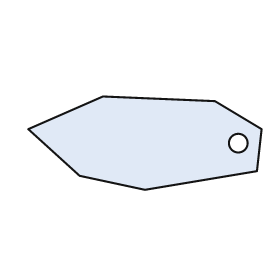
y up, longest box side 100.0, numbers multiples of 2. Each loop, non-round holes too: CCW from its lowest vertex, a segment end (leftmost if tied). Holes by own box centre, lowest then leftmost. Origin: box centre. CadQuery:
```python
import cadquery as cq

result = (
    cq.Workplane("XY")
    .moveTo(0.0, -20.0)
    .lineTo(48.0, -12.0)
    .lineTo(50.0, 6.0)
    .lineTo(30.0, 18.0)
    .lineTo(-18.0, 20.0)
    .lineTo(-50.0, 6.0)
    .lineTo(-28.0, -14.0)
    .close()
    .moveTo(40.0, 0.0)
    .circle(4.0)
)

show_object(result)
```